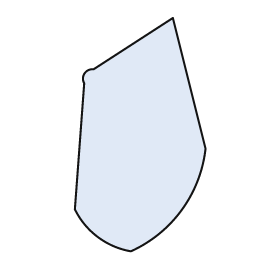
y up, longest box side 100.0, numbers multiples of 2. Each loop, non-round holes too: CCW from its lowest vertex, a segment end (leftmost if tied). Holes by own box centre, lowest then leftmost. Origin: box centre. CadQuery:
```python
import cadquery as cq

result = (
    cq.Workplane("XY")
    .moveTo(-4.0, -50.0)
    .threePointArc((18.0, -32.0), (28.0, -6.0))
    .lineTo(14.0, 50.0)
    .lineTo(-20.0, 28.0)
    .threePointArc((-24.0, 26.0), (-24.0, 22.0))
    .lineTo(-28.0, -32.0)
    .threePointArc((-18.0, -44.0), (-4.0, -50.0))
    .close()
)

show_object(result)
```